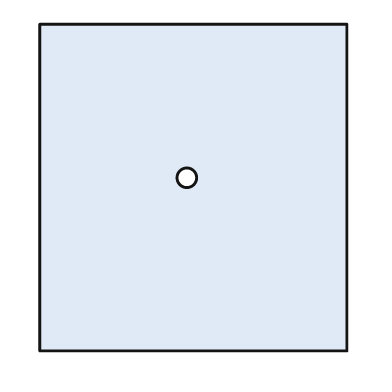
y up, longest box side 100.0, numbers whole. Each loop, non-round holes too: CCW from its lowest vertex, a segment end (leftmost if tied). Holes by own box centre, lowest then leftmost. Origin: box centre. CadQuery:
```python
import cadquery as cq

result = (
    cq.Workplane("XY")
    .moveTo(-47.0, -50.0)
    .lineTo(47.0, -50.0)
    .lineTo(47.0, 50.0)
    .lineTo(-47.0, 50.0)
    .close()
    .moveTo(-2.0, 3.0)
    .circle(3.0)
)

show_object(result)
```